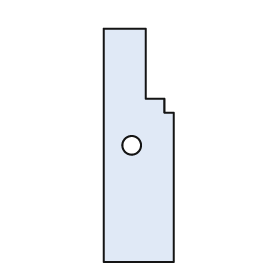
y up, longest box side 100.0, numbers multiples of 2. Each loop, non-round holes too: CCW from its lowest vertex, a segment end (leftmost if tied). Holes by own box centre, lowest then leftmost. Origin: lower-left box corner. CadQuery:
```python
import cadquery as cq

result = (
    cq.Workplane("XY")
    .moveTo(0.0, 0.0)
    .lineTo(30.0, 0.0)
    .lineTo(30.0, 64.0)
    .lineTo(26.0, 64.0)
    .lineTo(26.0, 70.0)
    .lineTo(18.0, 70.0)
    .lineTo(18.0, 100.0)
    .lineTo(0.0, 100.0)
    .close()
    .moveTo(12.0, 50.0)
    .circle(4.0)
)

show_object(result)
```